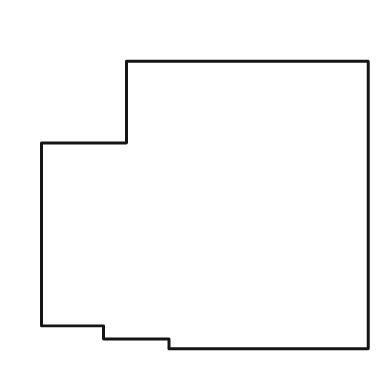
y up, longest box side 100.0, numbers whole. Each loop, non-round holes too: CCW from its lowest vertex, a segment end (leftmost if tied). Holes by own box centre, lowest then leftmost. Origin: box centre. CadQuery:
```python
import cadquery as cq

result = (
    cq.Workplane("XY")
    .moveTo(-11.0, -44.0)
    .lineTo(50.0, -44.0)
    .lineTo(50.0, 44.0)
    .lineTo(-24.0, 44.0)
    .lineTo(-24.0, 19.0)
    .lineTo(-50.0, 19.0)
    .lineTo(-50.0, -37.0)
    .lineTo(-31.0, -37.0)
    .lineTo(-31.0, -41.0)
    .lineTo(-11.0, -41.0)
    .close()
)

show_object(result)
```